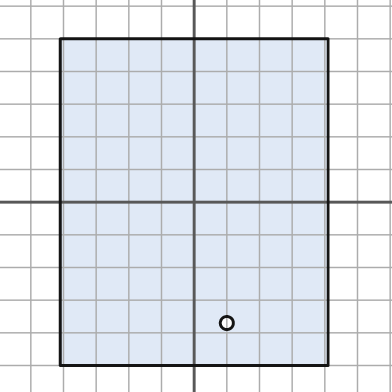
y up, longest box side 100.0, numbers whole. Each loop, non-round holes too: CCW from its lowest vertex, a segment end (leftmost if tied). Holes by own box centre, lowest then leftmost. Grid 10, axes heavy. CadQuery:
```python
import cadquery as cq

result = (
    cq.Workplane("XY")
    .moveTo(-41.0, -50.0)
    .lineTo(41.0, -50.0)
    .lineTo(41.0, 50.0)
    .lineTo(-41.0, 50.0)
    .close()
    .moveTo(10.0, -37.0)
    .circle(2.0)
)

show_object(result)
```